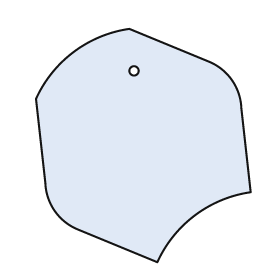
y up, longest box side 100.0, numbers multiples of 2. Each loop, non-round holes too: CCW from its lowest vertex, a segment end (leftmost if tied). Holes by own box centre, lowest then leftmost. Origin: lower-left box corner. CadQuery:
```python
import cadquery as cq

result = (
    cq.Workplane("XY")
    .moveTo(52.0, 0.0)
    .threePointArc((68.0, 20.0), (92.0, 30.0))
    .lineTo(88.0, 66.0)
    .threePointArc((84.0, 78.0), (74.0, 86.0))
    .lineTo(40.0, 100.0)
    .threePointArc((16.0, 90.0), (0.0, 70.0))
    .lineTo(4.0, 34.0)
    .threePointArc((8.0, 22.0), (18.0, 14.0))
    .close()
    .moveTo(42.0, 82.0)
    .circle(2.0)
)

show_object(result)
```